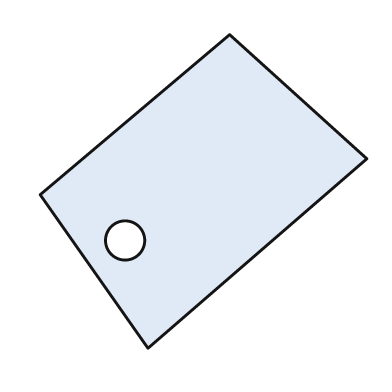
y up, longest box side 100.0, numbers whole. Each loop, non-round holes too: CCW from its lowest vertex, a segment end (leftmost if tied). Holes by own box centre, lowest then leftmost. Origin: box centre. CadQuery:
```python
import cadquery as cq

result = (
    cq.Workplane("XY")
    .moveTo(-17.0, -48.0)
    .lineTo(50.0, 10.0)
    .lineTo(8.0, 48.0)
    .lineTo(-50.0, -1.0)
    .close()
    .moveTo(-24.0, -15.0)
    .circle(6.0)
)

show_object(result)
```